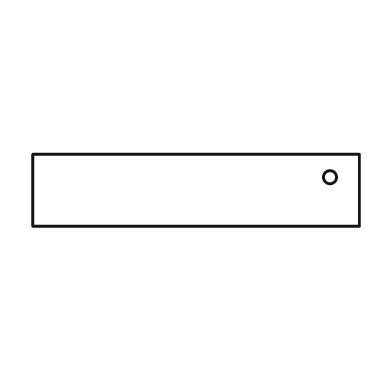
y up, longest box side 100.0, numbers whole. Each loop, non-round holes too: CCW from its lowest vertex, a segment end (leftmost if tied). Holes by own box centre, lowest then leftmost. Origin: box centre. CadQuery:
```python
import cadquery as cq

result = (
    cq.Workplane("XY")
    .moveTo(-50.0, -11.0)
    .lineTo(50.0, -11.0)
    .lineTo(50.0, 11.0)
    .lineTo(-50.0, 11.0)
    .close()
    .moveTo(41.0, 4.0)
    .circle(2.0)
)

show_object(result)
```